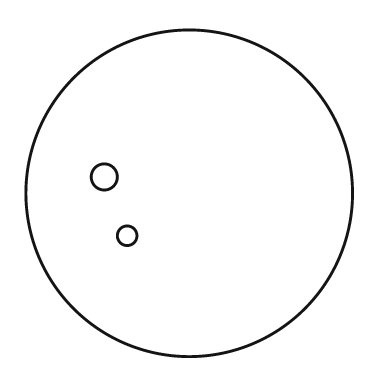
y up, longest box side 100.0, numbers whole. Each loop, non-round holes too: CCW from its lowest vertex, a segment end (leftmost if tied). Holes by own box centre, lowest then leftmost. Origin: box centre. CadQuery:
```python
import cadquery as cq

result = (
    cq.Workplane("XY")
    .moveTo(0.0, 0.0)
    .circle(50.0)
    .moveTo(-19.0, -13.0)
    .circle(3.0)
    .moveTo(-26.0, 5.0)
    .circle(4.0)
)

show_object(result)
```